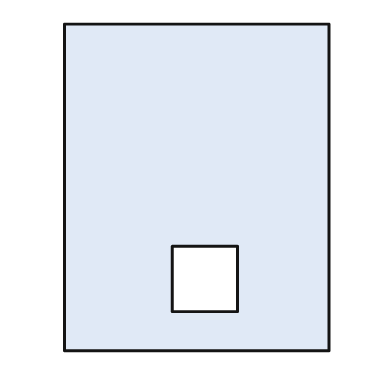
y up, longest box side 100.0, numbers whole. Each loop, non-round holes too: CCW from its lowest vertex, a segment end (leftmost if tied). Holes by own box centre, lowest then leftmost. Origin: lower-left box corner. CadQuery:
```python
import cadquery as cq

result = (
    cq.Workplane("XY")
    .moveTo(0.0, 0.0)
    .lineTo(81.0, 0.0)
    .lineTo(81.0, 100.0)
    .lineTo(0.0, 100.0)
    .close()
    .moveTo(33.0, 12.0)
    .lineTo(53.0, 12.0)
    .lineTo(53.0, 32.0)
    .lineTo(33.0, 32.0)
    .close()
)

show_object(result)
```